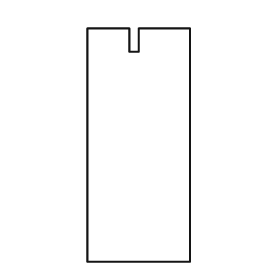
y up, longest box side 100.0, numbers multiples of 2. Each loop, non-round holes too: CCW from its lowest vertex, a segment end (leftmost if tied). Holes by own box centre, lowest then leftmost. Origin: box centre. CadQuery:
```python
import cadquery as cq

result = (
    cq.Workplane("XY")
    .moveTo(-22.0, -50.0)
    .lineTo(22.0, -50.0)
    .lineTo(22.0, 50.0)
    .lineTo(0.0, 50.0)
    .lineTo(0.0, 40.0)
    .lineTo(-4.0, 40.0)
    .lineTo(-4.0, 50.0)
    .lineTo(-22.0, 50.0)
    .close()
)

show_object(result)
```